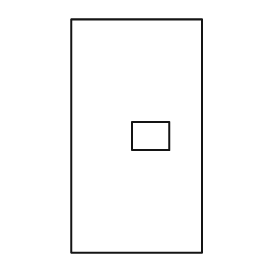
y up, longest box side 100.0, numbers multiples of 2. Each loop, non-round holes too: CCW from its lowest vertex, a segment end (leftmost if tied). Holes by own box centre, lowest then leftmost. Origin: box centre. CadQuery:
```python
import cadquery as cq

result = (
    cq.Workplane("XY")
    .moveTo(-28.0, -50.0)
    .lineTo(28.0, -50.0)
    .lineTo(28.0, 50.0)
    .lineTo(-28.0, 50.0)
    .close()
    .moveTo(-2.0, -6.0)
    .lineTo(14.0, -6.0)
    .lineTo(14.0, 6.0)
    .lineTo(-2.0, 6.0)
    .close()
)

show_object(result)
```